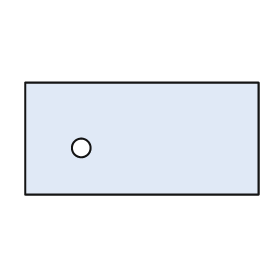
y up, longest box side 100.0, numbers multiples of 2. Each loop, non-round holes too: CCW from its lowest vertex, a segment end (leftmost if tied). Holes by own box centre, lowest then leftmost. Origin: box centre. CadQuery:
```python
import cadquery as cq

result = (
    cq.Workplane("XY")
    .moveTo(-50.0, -24.0)
    .lineTo(50.0, -24.0)
    .lineTo(50.0, 24.0)
    .lineTo(-50.0, 24.0)
    .close()
    .moveTo(-26.0, -4.0)
    .circle(4.0)
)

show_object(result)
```